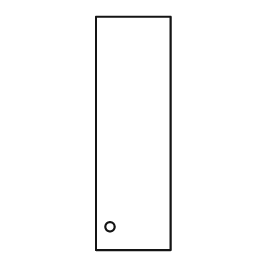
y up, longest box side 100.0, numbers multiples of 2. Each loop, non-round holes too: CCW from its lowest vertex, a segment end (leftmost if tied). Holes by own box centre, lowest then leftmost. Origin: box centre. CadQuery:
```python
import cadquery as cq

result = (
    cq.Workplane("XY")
    .moveTo(-16.0, -50.0)
    .lineTo(16.0, -50.0)
    .lineTo(16.0, 50.0)
    .lineTo(-16.0, 50.0)
    .close()
    .moveTo(-10.0, -40.0)
    .circle(2.0)
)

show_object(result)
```